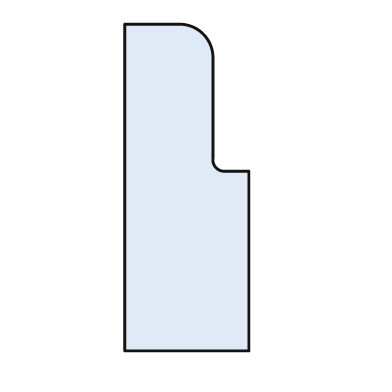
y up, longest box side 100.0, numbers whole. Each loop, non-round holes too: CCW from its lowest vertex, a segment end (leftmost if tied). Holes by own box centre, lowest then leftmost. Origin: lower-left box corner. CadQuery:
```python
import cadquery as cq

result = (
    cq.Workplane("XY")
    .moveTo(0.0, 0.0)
    .lineTo(38.0, 0.0)
    .lineTo(38.0, 55.0)
    .lineTo(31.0, 55.0)
    .threePointArc((28.0, 56.0), (27.0, 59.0))
    .lineTo(27.0, 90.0)
    .threePointArc((24.0, 97.0), (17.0, 100.0))
    .lineTo(0.0, 100.0)
    .close()
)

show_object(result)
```